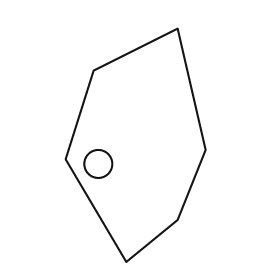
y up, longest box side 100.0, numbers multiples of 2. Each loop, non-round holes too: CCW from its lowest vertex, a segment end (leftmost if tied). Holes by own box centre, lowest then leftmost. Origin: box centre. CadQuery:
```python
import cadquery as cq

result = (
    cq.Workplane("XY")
    .moveTo(-4.0, -50.0)
    .lineTo(18.0, -32.0)
    .lineTo(30.0, -2.0)
    .lineTo(18.0, 50.0)
    .lineTo(-18.0, 32.0)
    .lineTo(-30.0, -6.0)
    .close()
    .moveTo(-16.0, -8.0)
    .circle(6.0)
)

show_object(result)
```